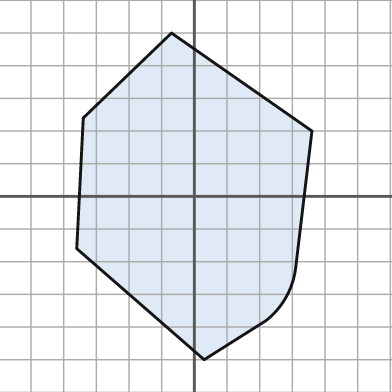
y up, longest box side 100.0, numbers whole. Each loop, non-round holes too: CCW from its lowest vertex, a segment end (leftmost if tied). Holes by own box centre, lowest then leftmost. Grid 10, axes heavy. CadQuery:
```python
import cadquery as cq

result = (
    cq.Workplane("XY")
    .moveTo(3.0, -50.0)
    .lineTo(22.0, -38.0)
    .threePointArc((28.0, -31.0), (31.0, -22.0))
    .lineTo(36.0, 20.0)
    .lineTo(-7.0, 50.0)
    .lineTo(-34.0, 24.0)
    .lineTo(-36.0, -16.0)
    .close()
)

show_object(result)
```